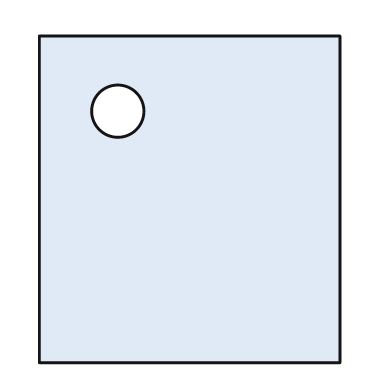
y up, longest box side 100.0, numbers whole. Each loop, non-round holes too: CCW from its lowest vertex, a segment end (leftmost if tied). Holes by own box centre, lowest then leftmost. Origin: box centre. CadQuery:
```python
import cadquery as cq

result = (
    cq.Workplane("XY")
    .moveTo(-46.0, -50.0)
    .lineTo(46.0, -50.0)
    .lineTo(46.0, 50.0)
    .lineTo(-46.0, 50.0)
    .close()
    .moveTo(-22.0, 27.0)
    .circle(8.0)
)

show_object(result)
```